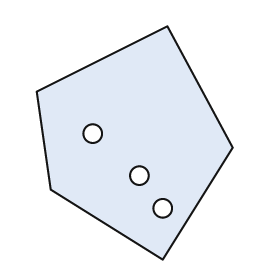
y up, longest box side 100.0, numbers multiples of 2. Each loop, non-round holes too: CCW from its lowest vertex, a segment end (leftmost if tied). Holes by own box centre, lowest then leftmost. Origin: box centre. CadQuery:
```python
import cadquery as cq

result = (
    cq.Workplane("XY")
    .moveTo(12.0, -50.0)
    .lineTo(42.0, -2.0)
    .lineTo(14.0, 50.0)
    .lineTo(-42.0, 22.0)
    .lineTo(-36.0, -20.0)
    .close()
    .moveTo(12.0, -28.0)
    .circle(4.0)
    .moveTo(2.0, -14.0)
    .circle(4.0)
    .moveTo(-18.0, 4.0)
    .circle(4.0)
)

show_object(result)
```